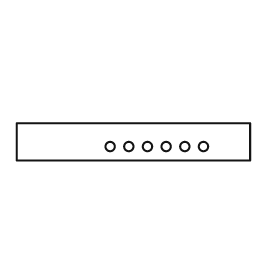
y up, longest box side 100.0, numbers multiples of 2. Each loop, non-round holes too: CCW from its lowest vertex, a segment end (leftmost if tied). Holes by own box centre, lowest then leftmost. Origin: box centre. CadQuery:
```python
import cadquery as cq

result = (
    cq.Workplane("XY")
    .moveTo(-50.0, -8.0)
    .lineTo(50.0, -8.0)
    .lineTo(50.0, 8.0)
    .lineTo(-50.0, 8.0)
    .close()
    .moveTo(-10.0, -2.0)
    .circle(2.0)
    .moveTo(-2.0, -2.0)
    .circle(2.0)
    .moveTo(6.0, -2.0)
    .circle(2.0)
    .moveTo(14.0, -2.0)
    .circle(2.0)
    .moveTo(22.0, -2.0)
    .circle(2.0)
    .moveTo(30.0, -2.0)
    .circle(2.0)
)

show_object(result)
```